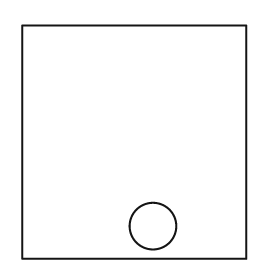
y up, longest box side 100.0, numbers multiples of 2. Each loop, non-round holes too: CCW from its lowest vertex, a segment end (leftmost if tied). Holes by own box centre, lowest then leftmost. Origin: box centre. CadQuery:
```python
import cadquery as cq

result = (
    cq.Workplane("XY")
    .moveTo(-48.0, -50.0)
    .lineTo(48.0, -50.0)
    .lineTo(48.0, 50.0)
    .lineTo(-48.0, 50.0)
    .close()
    .moveTo(8.0, -36.0)
    .circle(10.0)
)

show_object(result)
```